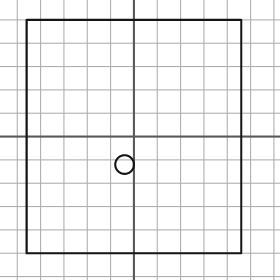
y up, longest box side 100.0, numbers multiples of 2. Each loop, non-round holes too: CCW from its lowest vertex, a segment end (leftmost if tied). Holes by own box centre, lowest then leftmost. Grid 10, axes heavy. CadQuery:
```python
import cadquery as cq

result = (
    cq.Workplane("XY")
    .moveTo(-46.0, -50.0)
    .lineTo(46.0, -50.0)
    .lineTo(46.0, 50.0)
    .lineTo(-46.0, 50.0)
    .close()
    .moveTo(-4.0, -12.0)
    .circle(4.0)
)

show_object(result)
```